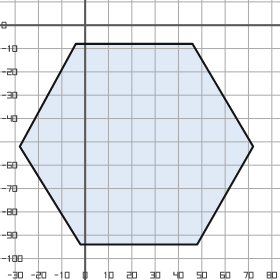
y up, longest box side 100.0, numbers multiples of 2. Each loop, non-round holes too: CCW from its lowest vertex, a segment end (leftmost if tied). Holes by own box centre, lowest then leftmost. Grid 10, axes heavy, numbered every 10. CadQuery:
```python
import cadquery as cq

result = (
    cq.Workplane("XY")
    .moveTo(-2.0, -94.0)
    .lineTo(48.0, -94.0)
    .lineTo(72.0, -52.0)
    .lineTo(46.0, -8.0)
    .lineTo(-4.0, -8.0)
    .lineTo(-28.0, -52.0)
    .close()
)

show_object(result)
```